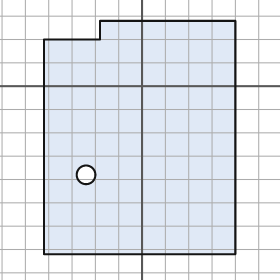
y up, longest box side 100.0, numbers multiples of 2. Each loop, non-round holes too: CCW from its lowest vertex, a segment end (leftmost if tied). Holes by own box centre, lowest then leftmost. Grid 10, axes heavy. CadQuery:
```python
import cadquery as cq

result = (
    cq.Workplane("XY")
    .moveTo(-42.0, -72.0)
    .lineTo(40.0, -72.0)
    .lineTo(40.0, 28.0)
    .lineTo(-18.0, 28.0)
    .lineTo(-18.0, 20.0)
    .lineTo(-42.0, 20.0)
    .close()
    .moveTo(-24.0, -38.0)
    .circle(4.0)
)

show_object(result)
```